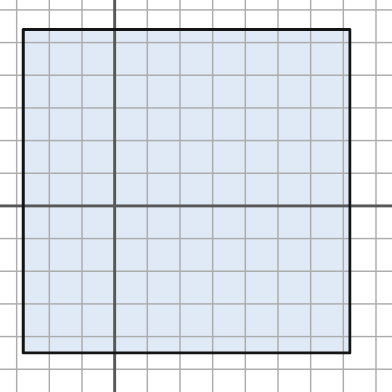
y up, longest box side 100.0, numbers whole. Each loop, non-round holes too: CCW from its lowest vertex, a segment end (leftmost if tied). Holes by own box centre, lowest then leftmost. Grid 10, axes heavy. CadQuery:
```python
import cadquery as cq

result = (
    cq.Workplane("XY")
    .moveTo(-28.0, -45.0)
    .lineTo(72.0, -45.0)
    .lineTo(72.0, 54.0)
    .lineTo(-28.0, 54.0)
    .close()
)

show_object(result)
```